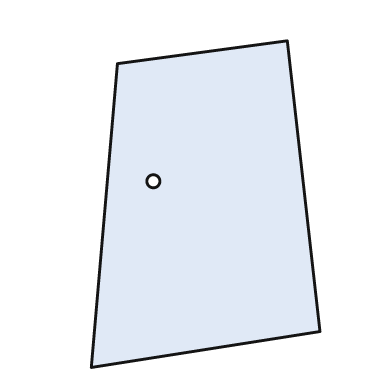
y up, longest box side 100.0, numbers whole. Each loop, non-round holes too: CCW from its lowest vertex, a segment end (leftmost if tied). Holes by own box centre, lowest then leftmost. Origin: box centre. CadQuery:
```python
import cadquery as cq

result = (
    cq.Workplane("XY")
    .moveTo(-35.0, -50.0)
    .lineTo(35.0, -39.0)
    .lineTo(25.0, 50.0)
    .lineTo(-27.0, 43.0)
    .close()
    .moveTo(-16.0, 7.0)
    .circle(2.0)
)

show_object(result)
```